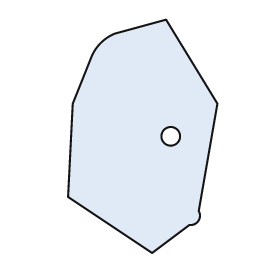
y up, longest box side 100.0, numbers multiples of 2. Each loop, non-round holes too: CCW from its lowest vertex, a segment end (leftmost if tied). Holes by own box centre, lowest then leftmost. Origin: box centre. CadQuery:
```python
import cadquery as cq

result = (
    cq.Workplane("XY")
    .moveTo(4.0, -50.0)
    .lineTo(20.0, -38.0)
    .threePointArc((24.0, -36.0), (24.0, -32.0))
    .lineTo(32.0, 14.0)
    .lineTo(10.0, 50.0)
    .lineTo(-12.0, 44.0)
    .threePointArc((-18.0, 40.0), (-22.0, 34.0))
    .lineTo(-30.0, 14.0)
    .lineTo(-32.0, -26.0)
    .close()
    .moveTo(12.0, 0.0)
    .circle(4.0)
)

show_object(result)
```